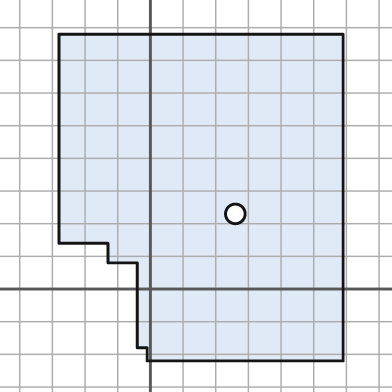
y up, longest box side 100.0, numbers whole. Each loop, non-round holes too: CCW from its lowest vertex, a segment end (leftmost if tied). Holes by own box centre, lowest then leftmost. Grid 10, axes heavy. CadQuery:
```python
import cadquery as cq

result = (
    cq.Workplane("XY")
    .moveTo(-1.0, -22.0)
    .lineTo(59.0, -22.0)
    .lineTo(59.0, 78.0)
    .lineTo(-28.0, 78.0)
    .lineTo(-28.0, 14.0)
    .lineTo(-13.0, 14.0)
    .lineTo(-13.0, 8.0)
    .lineTo(-4.0, 8.0)
    .lineTo(-4.0, -18.0)
    .lineTo(-1.0, -18.0)
    .close()
    .moveTo(26.0, 23.0)
    .circle(3.0)
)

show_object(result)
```